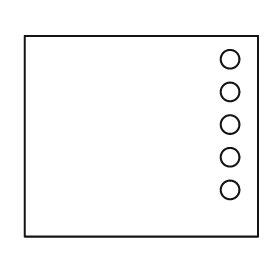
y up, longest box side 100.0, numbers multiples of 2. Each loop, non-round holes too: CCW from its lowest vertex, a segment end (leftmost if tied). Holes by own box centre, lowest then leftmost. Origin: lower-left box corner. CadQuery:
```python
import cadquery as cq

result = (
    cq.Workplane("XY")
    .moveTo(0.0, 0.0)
    .lineTo(100.0, 0.0)
    .lineTo(100.0, 86.0)
    .lineTo(0.0, 86.0)
    .close()
    .moveTo(88.0, 20.0)
    .circle(4.0)
    .moveTo(88.0, 34.0)
    .circle(4.0)
    .moveTo(88.0, 48.0)
    .circle(4.0)
    .moveTo(88.0, 62.0)
    .circle(4.0)
    .moveTo(88.0, 76.0)
    .circle(4.0)
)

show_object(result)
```